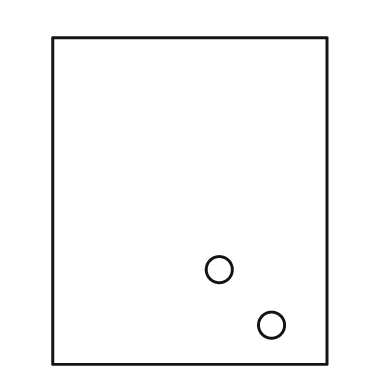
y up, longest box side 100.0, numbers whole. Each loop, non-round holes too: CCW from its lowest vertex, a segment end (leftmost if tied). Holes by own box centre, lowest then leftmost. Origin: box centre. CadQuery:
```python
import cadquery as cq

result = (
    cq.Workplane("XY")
    .moveTo(-42.0, -50.0)
    .lineTo(42.0, -50.0)
    .lineTo(42.0, 50.0)
    .lineTo(-42.0, 50.0)
    .close()
    .moveTo(25.0, -38.0)
    .circle(4.0)
    .moveTo(9.0, -21.0)
    .circle(4.0)
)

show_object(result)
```